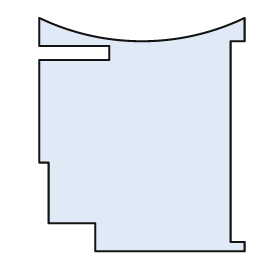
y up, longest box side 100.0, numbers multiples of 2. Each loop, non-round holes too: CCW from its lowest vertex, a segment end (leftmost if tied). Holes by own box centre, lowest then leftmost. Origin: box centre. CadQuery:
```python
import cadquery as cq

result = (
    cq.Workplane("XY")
    .moveTo(-20.0, -50.0)
    .lineTo(44.0, -50.0)
    .lineTo(44.0, -46.0)
    .lineTo(38.0, -46.0)
    .lineTo(38.0, 40.0)
    .lineTo(44.0, 40.0)
    .lineTo(44.0, 50.0)
    .threePointArc((0.0, 40.0), (-44.0, 50.0))
    .lineTo(-44.0, 38.0)
    .lineTo(-14.0, 38.0)
    .lineTo(-14.0, 32.0)
    .lineTo(-44.0, 32.0)
    .lineTo(-44.0, -12.0)
    .lineTo(-40.0, -12.0)
    .lineTo(-40.0, -38.0)
    .lineTo(-20.0, -38.0)
    .close()
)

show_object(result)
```